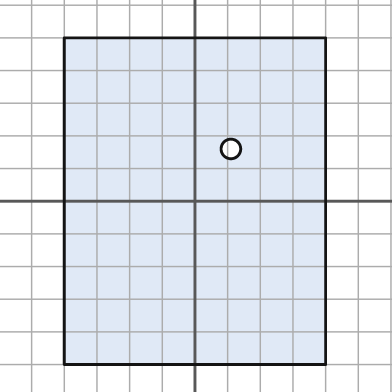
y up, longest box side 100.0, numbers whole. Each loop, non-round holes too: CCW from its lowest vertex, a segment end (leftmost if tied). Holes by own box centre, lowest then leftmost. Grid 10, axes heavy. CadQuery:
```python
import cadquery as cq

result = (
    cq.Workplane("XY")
    .moveTo(-40.0, -50.0)
    .lineTo(40.0, -50.0)
    .lineTo(40.0, 50.0)
    .lineTo(-40.0, 50.0)
    .close()
    .moveTo(11.0, 16.0)
    .circle(3.0)
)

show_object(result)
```